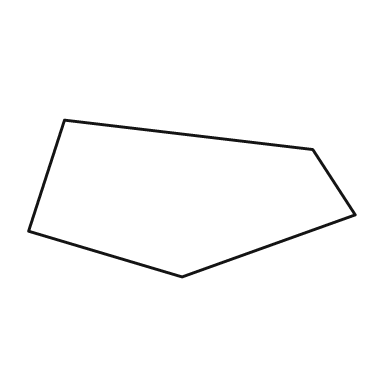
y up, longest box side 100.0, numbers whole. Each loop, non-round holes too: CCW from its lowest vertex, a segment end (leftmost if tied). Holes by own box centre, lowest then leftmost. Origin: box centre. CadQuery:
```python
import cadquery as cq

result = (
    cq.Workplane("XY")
    .moveTo(-3.0, -24.0)
    .lineTo(50.0, -5.0)
    .lineTo(37.0, 15.0)
    .lineTo(-39.0, 24.0)
    .lineTo(-50.0, -10.0)
    .close()
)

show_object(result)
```